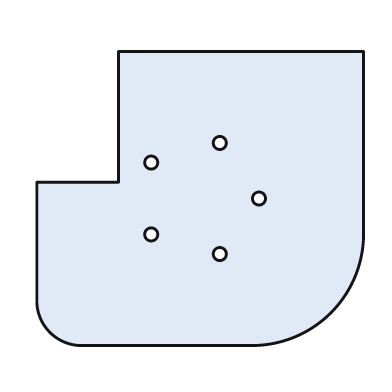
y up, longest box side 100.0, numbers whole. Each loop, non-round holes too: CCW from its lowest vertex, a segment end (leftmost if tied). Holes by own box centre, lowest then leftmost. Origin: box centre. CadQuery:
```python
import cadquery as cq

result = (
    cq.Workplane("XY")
    .moveTo(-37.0, -45.0)
    .lineTo(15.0, -45.0)
    .threePointArc((40.0, -35.0), (50.0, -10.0))
    .lineTo(50.0, 45.0)
    .lineTo(-25.0, 45.0)
    .lineTo(-25.0, 5.0)
    .lineTo(-50.0, 5.0)
    .lineTo(-50.0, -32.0)
    .threePointArc((-46.0, -41.0), (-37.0, -45.0))
    .close()
    .moveTo(6.0, -17.0)
    .circle(2.0)
    .moveTo(-15.0, -11.0)
    .circle(2.0)
    .moveTo(18.0, 0.0)
    .circle(2.0)
    .moveTo(-15.0, 11.0)
    .circle(2.0)
    .moveTo(6.0, 17.0)
    .circle(2.0)
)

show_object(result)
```